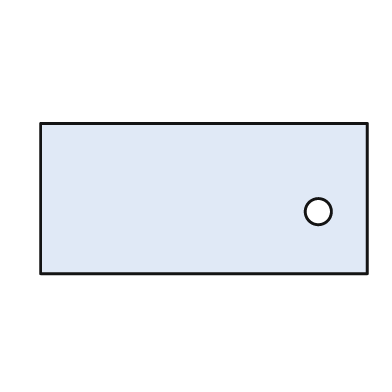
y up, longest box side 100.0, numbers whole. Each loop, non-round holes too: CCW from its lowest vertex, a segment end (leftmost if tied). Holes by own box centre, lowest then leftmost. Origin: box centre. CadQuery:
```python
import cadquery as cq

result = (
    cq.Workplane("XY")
    .moveTo(-50.0, -23.0)
    .lineTo(50.0, -23.0)
    .lineTo(50.0, 23.0)
    .lineTo(-50.0, 23.0)
    .close()
    .moveTo(35.0, -4.0)
    .circle(4.0)
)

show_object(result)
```